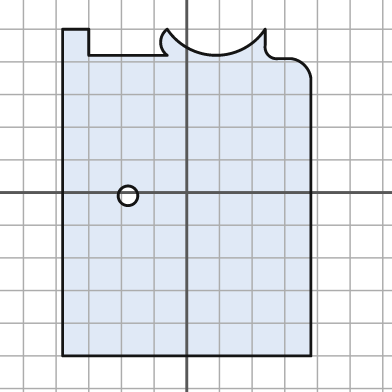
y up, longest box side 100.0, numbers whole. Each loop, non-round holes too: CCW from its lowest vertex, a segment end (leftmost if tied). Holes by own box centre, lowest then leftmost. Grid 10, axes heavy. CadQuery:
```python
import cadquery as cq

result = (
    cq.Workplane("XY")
    .moveTo(-38.0, -50.0)
    .lineTo(38.0, -50.0)
    .lineTo(38.0, 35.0)
    .threePointArc((36.0, 39.0), (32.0, 41.0))
    .lineTo(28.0, 41.0)
    .threePointArc((25.0, 42.0), (24.0, 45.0))
    .lineTo(24.0, 50.0)
    .threePointArc((9.0, 42.0), (-6.0, 50.0))
    .threePointArc((-8.0, 46.0), (-6.0, 42.0))
    .lineTo(-30.0, 42.0)
    .lineTo(-30.0, 50.0)
    .lineTo(-38.0, 50.0)
    .close()
    .moveTo(-18.0, -1.0)
    .circle(3.0)
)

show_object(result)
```